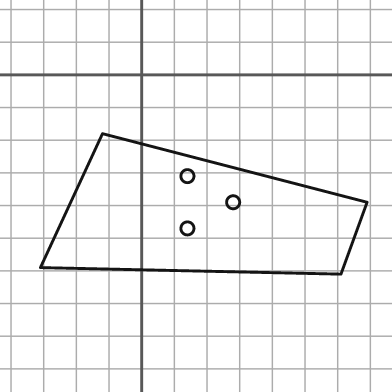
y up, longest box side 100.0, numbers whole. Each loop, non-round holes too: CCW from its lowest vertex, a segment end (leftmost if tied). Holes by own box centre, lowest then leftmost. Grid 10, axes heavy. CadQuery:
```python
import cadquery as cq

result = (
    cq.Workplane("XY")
    .moveTo(61.0, -61.0)
    .lineTo(69.0, -39.0)
    .lineTo(-12.0, -18.0)
    .lineTo(-31.0, -59.0)
    .close()
    .moveTo(14.0, -47.0)
    .circle(2.0)
    .moveTo(28.0, -39.0)
    .circle(2.0)
    .moveTo(14.0, -31.0)
    .circle(2.0)
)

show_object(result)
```